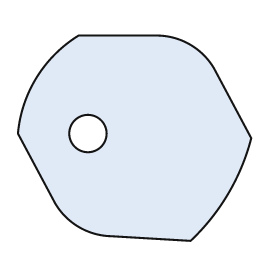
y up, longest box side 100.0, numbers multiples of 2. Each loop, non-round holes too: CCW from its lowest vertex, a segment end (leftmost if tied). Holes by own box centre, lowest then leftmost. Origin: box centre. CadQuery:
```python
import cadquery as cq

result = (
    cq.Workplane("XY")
    .moveTo(24.0, -44.0)
    .threePointArc((40.0, -24.0), (50.0, 0.0))
    .lineTo(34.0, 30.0)
    .threePointArc((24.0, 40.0), (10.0, 44.0))
    .lineTo(-24.0, 44.0)
    .threePointArc((-42.0, 26.0), (-50.0, 2.0))
    .lineTo(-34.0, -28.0)
    .threePointArc((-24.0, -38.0), (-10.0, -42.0))
    .close()
    .moveTo(-20.0, 2.0)
    .circle(8.0)
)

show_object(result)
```